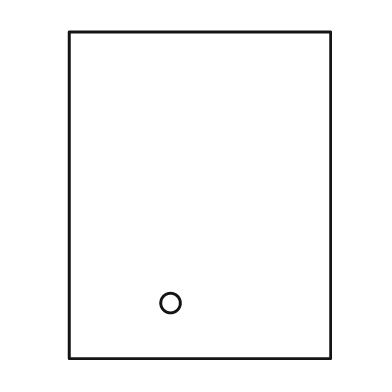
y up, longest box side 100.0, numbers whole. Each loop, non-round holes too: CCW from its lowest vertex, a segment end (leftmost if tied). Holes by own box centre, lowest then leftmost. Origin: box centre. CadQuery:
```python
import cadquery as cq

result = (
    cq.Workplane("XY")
    .moveTo(-40.0, -50.0)
    .lineTo(40.0, -50.0)
    .lineTo(40.0, 50.0)
    .lineTo(-40.0, 50.0)
    .close()
    .moveTo(-9.0, -33.0)
    .circle(3.0)
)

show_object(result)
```